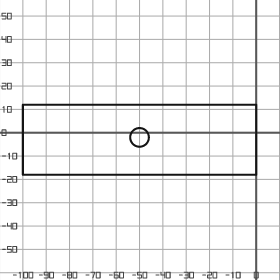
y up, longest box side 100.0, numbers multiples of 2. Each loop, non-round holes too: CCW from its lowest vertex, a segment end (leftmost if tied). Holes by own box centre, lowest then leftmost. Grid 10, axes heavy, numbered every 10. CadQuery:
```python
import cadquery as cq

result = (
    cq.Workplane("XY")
    .moveTo(-100.0, -18.0)
    .lineTo(0.0, -18.0)
    .lineTo(0.0, 12.0)
    .lineTo(-100.0, 12.0)
    .close()
    .moveTo(-50.0, -2.0)
    .circle(4.0)
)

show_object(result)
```